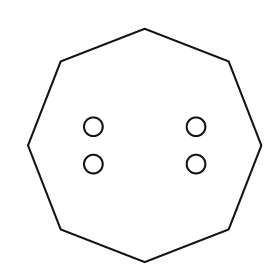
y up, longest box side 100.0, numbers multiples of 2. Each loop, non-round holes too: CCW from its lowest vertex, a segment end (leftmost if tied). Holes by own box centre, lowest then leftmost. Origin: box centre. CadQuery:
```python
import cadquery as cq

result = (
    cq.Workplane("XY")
    .moveTo(0.0, -50.0)
    .lineTo(36.0, -36.0)
    .lineTo(50.0, 0.0)
    .lineTo(36.0, 36.0)
    .lineTo(0.0, 50.0)
    .lineTo(-36.0, 36.0)
    .lineTo(-50.0, 0.0)
    .lineTo(-36.0, -36.0)
    .close()
    .moveTo(-22.0, -8.0)
    .circle(4.0)
    .moveTo(22.0, -8.0)
    .circle(4.0)
    .moveTo(-22.0, 8.0)
    .circle(4.0)
    .moveTo(22.0, 8.0)
    .circle(4.0)
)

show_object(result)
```